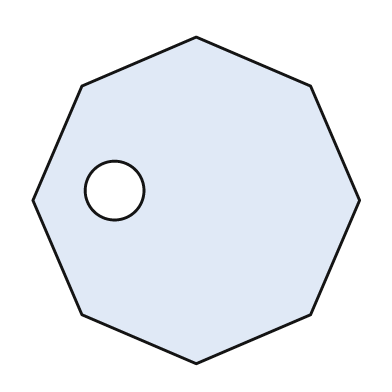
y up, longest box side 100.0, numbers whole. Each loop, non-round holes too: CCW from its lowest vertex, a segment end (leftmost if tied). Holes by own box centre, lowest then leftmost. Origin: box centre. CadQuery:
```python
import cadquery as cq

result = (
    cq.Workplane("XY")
    .moveTo(0.0, -50.0)
    .lineTo(35.0, -35.0)
    .lineTo(50.0, 0.0)
    .lineTo(35.0, 35.0)
    .lineTo(0.0, 50.0)
    .lineTo(-35.0, 35.0)
    .lineTo(-50.0, 0.0)
    .lineTo(-35.0, -35.0)
    .close()
    .moveTo(-25.0, 3.0)
    .circle(9.0)
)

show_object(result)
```